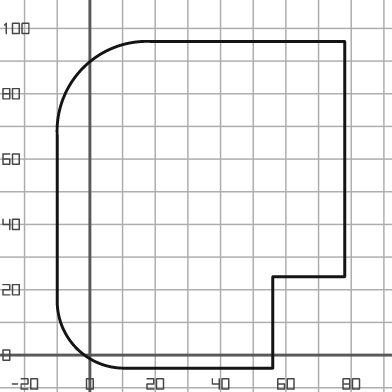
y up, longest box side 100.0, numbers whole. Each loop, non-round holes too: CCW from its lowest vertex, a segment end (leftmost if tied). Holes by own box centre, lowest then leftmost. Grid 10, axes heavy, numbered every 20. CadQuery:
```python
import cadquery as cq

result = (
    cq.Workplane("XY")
    .moveTo(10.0, -4.0)
    .lineTo(56.0, -4.0)
    .lineTo(56.0, 24.0)
    .lineTo(78.0, 24.0)
    .lineTo(78.0, 96.0)
    .lineTo(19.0, 96.0)
    .threePointArc((-2.0, 88.0), (-10.0, 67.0))
    .lineTo(-10.0, 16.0)
    .threePointArc((-4.0, 2.0), (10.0, -4.0))
    .close()
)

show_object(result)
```